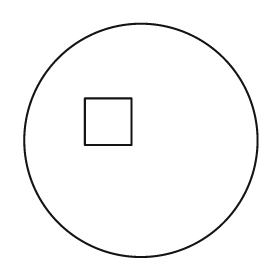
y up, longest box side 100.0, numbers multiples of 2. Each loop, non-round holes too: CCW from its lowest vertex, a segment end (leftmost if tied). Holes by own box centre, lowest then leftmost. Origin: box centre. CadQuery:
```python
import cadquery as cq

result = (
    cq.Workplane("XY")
    .moveTo(0.0, 0.0)
    .circle(50.0)
    .moveTo(-24.0, -2.0)
    .lineTo(-4.0, -2.0)
    .lineTo(-4.0, 18.0)
    .lineTo(-24.0, 18.0)
    .close()
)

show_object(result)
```